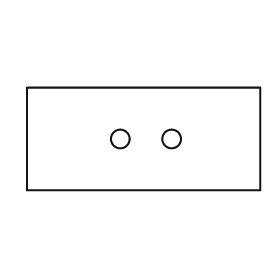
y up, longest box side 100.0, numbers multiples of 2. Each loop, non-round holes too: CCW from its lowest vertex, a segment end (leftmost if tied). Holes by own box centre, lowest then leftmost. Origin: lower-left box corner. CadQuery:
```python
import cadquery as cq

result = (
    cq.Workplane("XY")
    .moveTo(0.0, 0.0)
    .lineTo(100.0, 0.0)
    .lineTo(100.0, 44.0)
    .lineTo(0.0, 44.0)
    .close()
    .moveTo(40.0, 22.0)
    .circle(4.0)
    .moveTo(62.0, 22.0)
    .circle(4.0)
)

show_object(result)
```